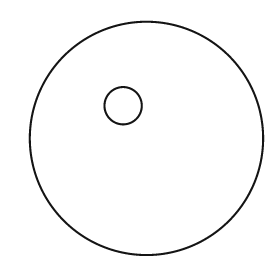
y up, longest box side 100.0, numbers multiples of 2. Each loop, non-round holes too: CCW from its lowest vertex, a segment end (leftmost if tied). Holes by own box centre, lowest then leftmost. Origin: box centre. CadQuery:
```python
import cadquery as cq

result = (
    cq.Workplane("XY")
    .moveTo(0.0, 0.0)
    .circle(50.0)
    .moveTo(-10.0, 14.0)
    .circle(8.0)
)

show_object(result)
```